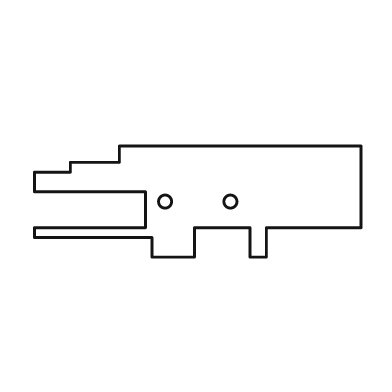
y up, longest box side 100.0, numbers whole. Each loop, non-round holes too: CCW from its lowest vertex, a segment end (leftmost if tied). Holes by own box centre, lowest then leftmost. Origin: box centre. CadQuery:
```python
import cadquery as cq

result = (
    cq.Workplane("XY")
    .moveTo(-14.0, -17.0)
    .lineTo(-1.0, -17.0)
    .lineTo(-1.0, -8.0)
    .lineTo(16.0, -8.0)
    .lineTo(16.0, -17.0)
    .lineTo(21.0, -17.0)
    .lineTo(21.0, -8.0)
    .lineTo(50.0, -8.0)
    .lineTo(50.0, 17.0)
    .lineTo(-24.0, 17.0)
    .lineTo(-24.0, 12.0)
    .lineTo(-39.0, 12.0)
    .lineTo(-39.0, 9.0)
    .lineTo(-50.0, 9.0)
    .lineTo(-50.0, 3.0)
    .lineTo(-16.0, 3.0)
    .lineTo(-16.0, -8.0)
    .lineTo(-50.0, -8.0)
    .lineTo(-50.0, -11.0)
    .lineTo(-14.0, -11.0)
    .close()
    .moveTo(-10.0, 0.0)
    .circle(2.0)
    .moveTo(10.0, 0.0)
    .circle(2.0)
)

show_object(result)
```